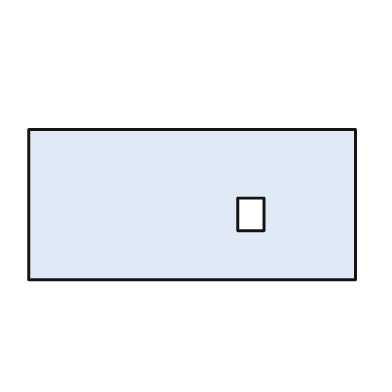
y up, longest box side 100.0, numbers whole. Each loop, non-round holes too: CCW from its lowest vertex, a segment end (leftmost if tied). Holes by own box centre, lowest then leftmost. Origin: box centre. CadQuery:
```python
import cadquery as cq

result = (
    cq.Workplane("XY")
    .moveTo(-50.0, -23.0)
    .lineTo(50.0, -23.0)
    .lineTo(50.0, 23.0)
    .lineTo(-50.0, 23.0)
    .close()
    .moveTo(14.0, -8.0)
    .lineTo(22.0, -8.0)
    .lineTo(22.0, 2.0)
    .lineTo(14.0, 2.0)
    .close()
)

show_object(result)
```